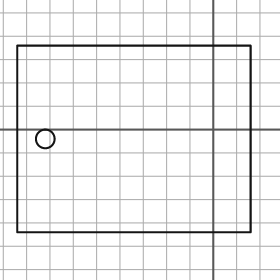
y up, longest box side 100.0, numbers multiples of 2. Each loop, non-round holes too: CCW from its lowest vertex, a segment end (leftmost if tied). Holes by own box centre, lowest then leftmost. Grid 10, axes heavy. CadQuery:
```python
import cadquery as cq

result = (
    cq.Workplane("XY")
    .moveTo(-84.0, -44.0)
    .lineTo(16.0, -44.0)
    .lineTo(16.0, 36.0)
    .lineTo(-84.0, 36.0)
    .close()
    .moveTo(-72.0, -4.0)
    .circle(4.0)
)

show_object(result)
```